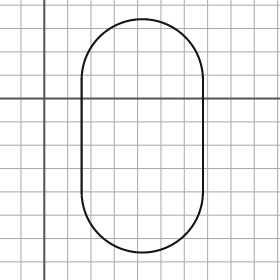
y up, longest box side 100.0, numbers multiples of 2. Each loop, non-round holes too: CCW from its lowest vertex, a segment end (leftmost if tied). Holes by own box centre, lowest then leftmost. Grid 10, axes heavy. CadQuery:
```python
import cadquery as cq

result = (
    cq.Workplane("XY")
    .moveTo(16.0, -40.0)
    .threePointArc((42.0, -66.0), (68.0, -40.0))
    .lineTo(68.0, 8.0)
    .threePointArc((42.0, 34.0), (16.0, 8.0))
    .close()
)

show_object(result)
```